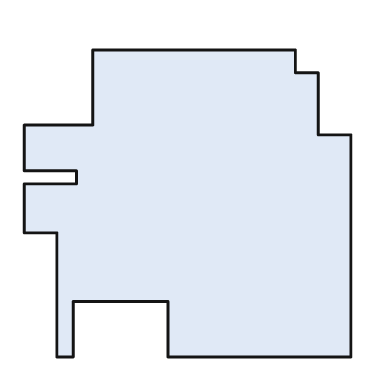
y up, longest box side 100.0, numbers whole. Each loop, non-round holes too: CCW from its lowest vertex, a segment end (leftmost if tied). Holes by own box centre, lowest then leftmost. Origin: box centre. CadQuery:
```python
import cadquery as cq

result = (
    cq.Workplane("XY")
    .moveTo(-40.0, -47.0)
    .lineTo(-35.0, -47.0)
    .lineTo(-35.0, -30.0)
    .lineTo(-6.0, -30.0)
    .lineTo(-6.0, -47.0)
    .lineTo(50.0, -47.0)
    .lineTo(50.0, 21.0)
    .lineTo(40.0, 21.0)
    .lineTo(40.0, 40.0)
    .lineTo(33.0, 40.0)
    .lineTo(33.0, 47.0)
    .lineTo(-29.0, 47.0)
    .lineTo(-29.0, 24.0)
    .lineTo(-50.0, 24.0)
    .lineTo(-50.0, 10.0)
    .lineTo(-34.0, 10.0)
    .lineTo(-34.0, 6.0)
    .lineTo(-50.0, 6.0)
    .lineTo(-50.0, -9.0)
    .lineTo(-40.0, -9.0)
    .close()
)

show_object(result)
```